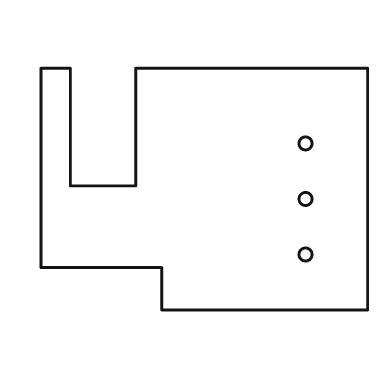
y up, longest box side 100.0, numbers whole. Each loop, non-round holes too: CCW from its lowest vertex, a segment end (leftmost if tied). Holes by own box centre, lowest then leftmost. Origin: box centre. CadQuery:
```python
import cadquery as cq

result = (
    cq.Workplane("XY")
    .moveTo(-13.0, -37.0)
    .lineTo(50.0, -37.0)
    .lineTo(50.0, 37.0)
    .lineTo(-21.0, 37.0)
    .lineTo(-21.0, 1.0)
    .lineTo(-41.0, 1.0)
    .lineTo(-41.0, 37.0)
    .lineTo(-50.0, 37.0)
    .lineTo(-50.0, -24.0)
    .lineTo(-13.0, -24.0)
    .close()
    .moveTo(31.0, -20.0)
    .circle(2.0)
    .moveTo(31.0, -3.0)
    .circle(2.0)
    .moveTo(31.0, 14.0)
    .circle(2.0)
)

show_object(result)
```